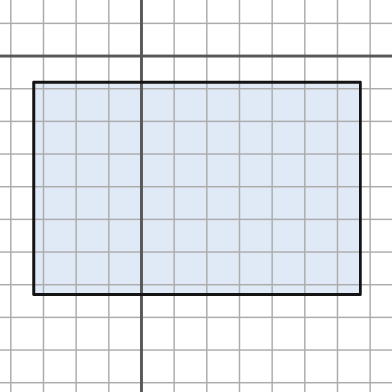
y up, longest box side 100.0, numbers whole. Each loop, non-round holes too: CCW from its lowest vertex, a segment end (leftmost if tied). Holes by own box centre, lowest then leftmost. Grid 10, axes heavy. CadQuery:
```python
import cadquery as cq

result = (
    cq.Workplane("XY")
    .moveTo(-33.0, -73.0)
    .lineTo(67.0, -73.0)
    .lineTo(67.0, -8.0)
    .lineTo(-33.0, -8.0)
    .close()
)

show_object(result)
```